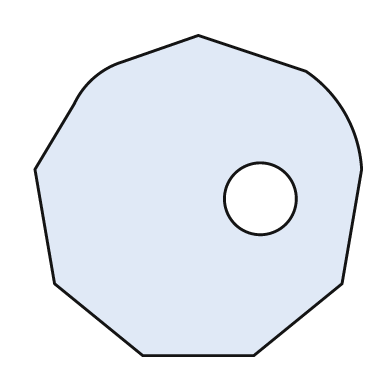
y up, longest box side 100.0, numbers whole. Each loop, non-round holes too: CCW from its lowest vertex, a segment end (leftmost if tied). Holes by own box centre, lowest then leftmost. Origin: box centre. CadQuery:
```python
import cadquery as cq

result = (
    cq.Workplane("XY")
    .moveTo(-17.0, -49.0)
    .lineTo(17.0, -49.0)
    .lineTo(44.0, -27.0)
    .lineTo(50.0, 8.0)
    .threePointArc((45.0, 25.0), (33.0, 38.0))
    .lineTo(0.0, 49.0)
    .lineTo(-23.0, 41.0)
    .threePointArc((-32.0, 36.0), (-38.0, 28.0))
    .lineTo(-50.0, 8.0)
    .lineTo(-44.0, -27.0)
    .close()
    .moveTo(19.0, -1.0)
    .circle(11.0)
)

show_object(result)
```